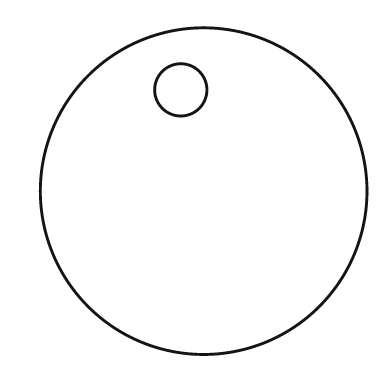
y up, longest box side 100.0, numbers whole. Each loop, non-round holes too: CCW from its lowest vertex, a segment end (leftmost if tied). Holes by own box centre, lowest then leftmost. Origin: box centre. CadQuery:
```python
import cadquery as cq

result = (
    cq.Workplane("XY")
    .moveTo(0.0, 0.0)
    .circle(50.0)
    .moveTo(-7.0, 31.0)
    .circle(8.0)
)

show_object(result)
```